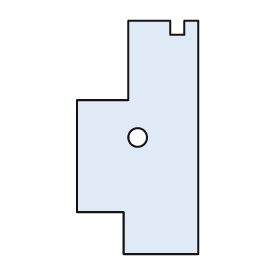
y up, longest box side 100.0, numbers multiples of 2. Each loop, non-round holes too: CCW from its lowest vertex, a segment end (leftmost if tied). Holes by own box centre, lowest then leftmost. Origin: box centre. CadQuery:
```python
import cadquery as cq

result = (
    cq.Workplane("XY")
    .moveTo(-6.0, -50.0)
    .lineTo(26.0, -50.0)
    .lineTo(26.0, 50.0)
    .lineTo(20.0, 50.0)
    .lineTo(20.0, 44.0)
    .lineTo(14.0, 44.0)
    .lineTo(14.0, 50.0)
    .lineTo(-4.0, 50.0)
    .lineTo(-4.0, 16.0)
    .lineTo(-26.0, 16.0)
    .lineTo(-26.0, -32.0)
    .lineTo(-6.0, -32.0)
    .close()
    .moveTo(0.0, 0.0)
    .circle(4.0)
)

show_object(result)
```